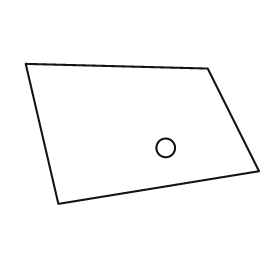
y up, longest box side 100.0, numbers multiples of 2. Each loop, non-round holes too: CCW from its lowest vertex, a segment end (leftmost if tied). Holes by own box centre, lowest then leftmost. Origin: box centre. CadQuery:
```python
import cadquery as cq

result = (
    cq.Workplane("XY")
    .moveTo(-36.0, -30.0)
    .lineTo(50.0, -16.0)
    .lineTo(28.0, 28.0)
    .lineTo(-50.0, 30.0)
    .close()
    .moveTo(10.0, -6.0)
    .circle(4.0)
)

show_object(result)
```